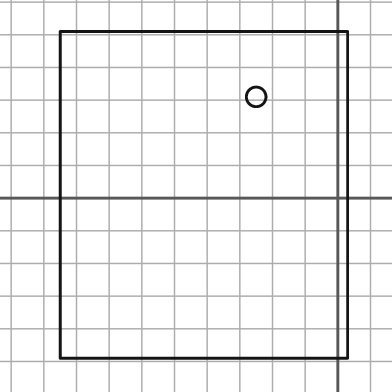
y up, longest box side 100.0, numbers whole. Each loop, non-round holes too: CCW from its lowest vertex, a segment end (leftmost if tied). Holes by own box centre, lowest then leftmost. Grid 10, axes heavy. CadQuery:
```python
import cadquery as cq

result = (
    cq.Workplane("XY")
    .moveTo(-85.0, -49.0)
    .lineTo(3.0, -49.0)
    .lineTo(3.0, 51.0)
    .lineTo(-85.0, 51.0)
    .close()
    .moveTo(-25.0, 31.0)
    .circle(3.0)
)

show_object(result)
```